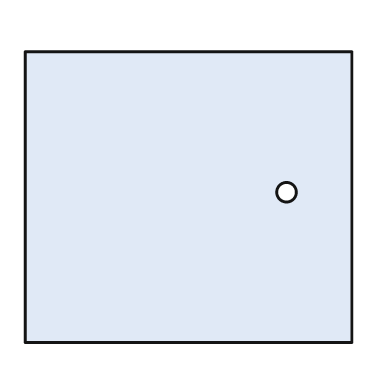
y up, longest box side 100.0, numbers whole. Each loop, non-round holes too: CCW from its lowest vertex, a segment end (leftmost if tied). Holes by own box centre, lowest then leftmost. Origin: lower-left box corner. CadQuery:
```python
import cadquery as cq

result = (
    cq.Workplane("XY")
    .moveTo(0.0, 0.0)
    .lineTo(100.0, 0.0)
    .lineTo(100.0, 89.0)
    .lineTo(0.0, 89.0)
    .close()
    .moveTo(80.0, 46.0)
    .circle(3.0)
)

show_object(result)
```